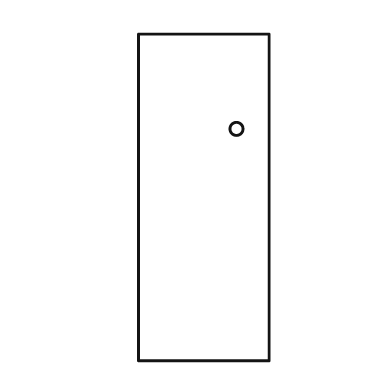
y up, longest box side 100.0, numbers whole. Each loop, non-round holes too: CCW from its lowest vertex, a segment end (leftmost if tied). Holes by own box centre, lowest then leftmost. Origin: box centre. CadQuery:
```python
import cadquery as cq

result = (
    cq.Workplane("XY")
    .moveTo(-20.0, -50.0)
    .lineTo(20.0, -50.0)
    .lineTo(20.0, 50.0)
    .lineTo(-20.0, 50.0)
    .close()
    .moveTo(10.0, 21.0)
    .circle(2.0)
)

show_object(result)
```